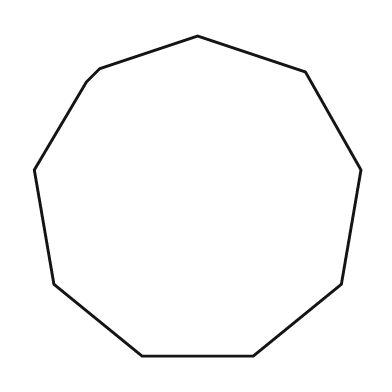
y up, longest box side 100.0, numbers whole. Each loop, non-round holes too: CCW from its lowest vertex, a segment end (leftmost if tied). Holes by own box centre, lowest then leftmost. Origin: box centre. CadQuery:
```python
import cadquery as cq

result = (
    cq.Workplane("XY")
    .moveTo(-17.0, -49.0)
    .lineTo(17.0, -49.0)
    .lineTo(44.0, -27.0)
    .lineTo(50.0, 8.0)
    .lineTo(33.0, 38.0)
    .lineTo(0.0, 49.0)
    .lineTo(-30.0, 39.0)
    .lineTo(-34.0, 35.0)
    .lineTo(-50.0, 8.0)
    .lineTo(-44.0, -27.0)
    .close()
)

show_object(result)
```